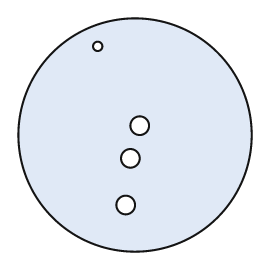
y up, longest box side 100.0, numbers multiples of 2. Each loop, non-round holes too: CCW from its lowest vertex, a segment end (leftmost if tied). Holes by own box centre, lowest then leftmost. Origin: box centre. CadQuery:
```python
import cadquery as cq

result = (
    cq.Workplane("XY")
    .moveTo(0.0, 0.0)
    .circle(50.0)
    .moveTo(-4.0, -30.0)
    .circle(4.0)
    .moveTo(-2.0, -10.0)
    .circle(4.0)
    .moveTo(2.0, 4.0)
    .circle(4.0)
    .moveTo(-16.0, 38.0)
    .circle(2.0)
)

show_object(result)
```